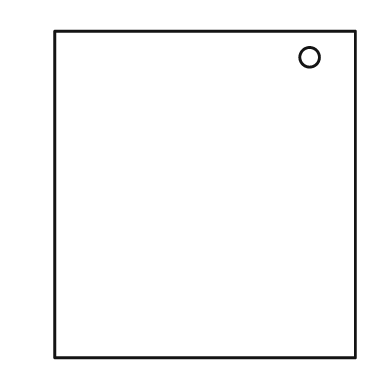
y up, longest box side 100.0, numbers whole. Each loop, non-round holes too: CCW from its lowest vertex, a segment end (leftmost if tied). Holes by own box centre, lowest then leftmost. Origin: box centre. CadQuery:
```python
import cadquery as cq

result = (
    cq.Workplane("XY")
    .moveTo(-46.0, -50.0)
    .lineTo(46.0, -50.0)
    .lineTo(46.0, 50.0)
    .lineTo(-46.0, 50.0)
    .close()
    .moveTo(32.0, 42.0)
    .circle(3.0)
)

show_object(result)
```